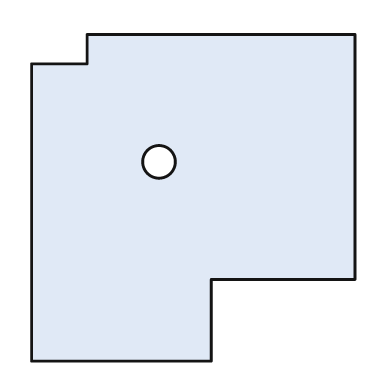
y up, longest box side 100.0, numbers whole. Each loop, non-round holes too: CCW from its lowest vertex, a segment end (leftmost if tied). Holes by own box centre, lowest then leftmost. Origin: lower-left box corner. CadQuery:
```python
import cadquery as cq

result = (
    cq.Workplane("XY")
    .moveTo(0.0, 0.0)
    .lineTo(55.0, 0.0)
    .lineTo(55.0, 25.0)
    .lineTo(99.0, 25.0)
    .lineTo(99.0, 100.0)
    .lineTo(17.0, 100.0)
    .lineTo(17.0, 91.0)
    .lineTo(0.0, 91.0)
    .close()
    .moveTo(39.0, 61.0)
    .circle(5.0)
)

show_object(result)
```